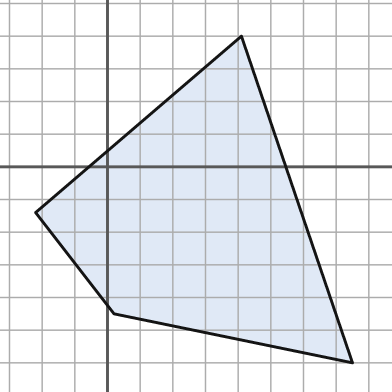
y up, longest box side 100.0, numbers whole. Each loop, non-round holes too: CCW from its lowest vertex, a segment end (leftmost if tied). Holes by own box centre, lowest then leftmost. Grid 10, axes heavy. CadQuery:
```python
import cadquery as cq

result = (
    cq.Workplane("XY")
    .moveTo(75.0, -60.0)
    .lineTo(41.0, 40.0)
    .lineTo(-22.0, -14.0)
    .lineTo(2.0, -45.0)
    .close()
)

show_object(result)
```